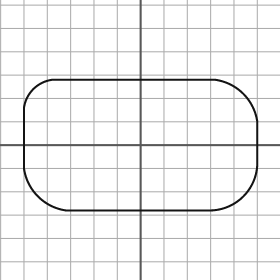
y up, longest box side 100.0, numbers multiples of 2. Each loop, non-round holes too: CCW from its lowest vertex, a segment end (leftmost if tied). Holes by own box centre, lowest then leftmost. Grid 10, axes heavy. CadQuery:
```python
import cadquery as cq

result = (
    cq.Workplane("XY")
    .moveTo(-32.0, -28.0)
    .lineTo(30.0, -28.0)
    .threePointArc((44.0, -22.0), (50.0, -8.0))
    .lineTo(50.0, 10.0)
    .threePointArc((44.0, 22.0), (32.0, 28.0))
    .lineTo(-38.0, 28.0)
    .threePointArc((-46.0, 24.0), (-50.0, 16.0))
    .lineTo(-50.0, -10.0)
    .threePointArc((-44.0, -22.0), (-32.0, -28.0))
    .close()
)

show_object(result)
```